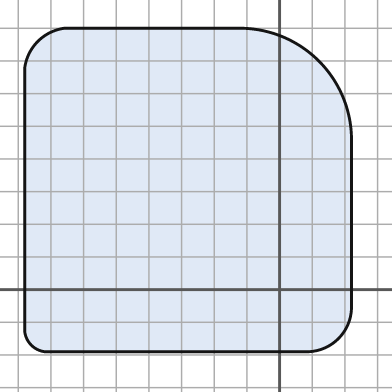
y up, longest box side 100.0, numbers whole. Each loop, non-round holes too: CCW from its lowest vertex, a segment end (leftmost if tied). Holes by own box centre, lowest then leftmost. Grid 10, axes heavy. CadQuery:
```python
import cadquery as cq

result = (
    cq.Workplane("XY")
    .moveTo(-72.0, -19.0)
    .lineTo(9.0, -19.0)
    .threePointArc((18.0, -15.0), (22.0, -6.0))
    .lineTo(22.0, 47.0)
    .threePointArc((12.0, 70.0), (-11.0, 80.0))
    .lineTo(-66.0, 80.0)
    .threePointArc((-74.0, 76.0), (-78.0, 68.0))
    .lineTo(-78.0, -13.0)
    .threePointArc((-76.0, -17.0), (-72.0, -19.0))
    .close()
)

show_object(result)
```